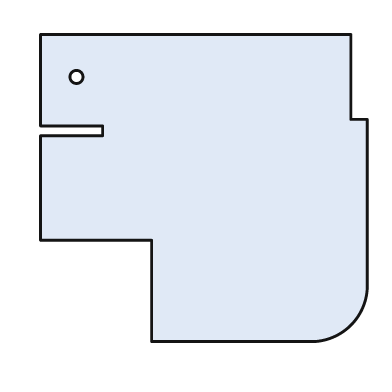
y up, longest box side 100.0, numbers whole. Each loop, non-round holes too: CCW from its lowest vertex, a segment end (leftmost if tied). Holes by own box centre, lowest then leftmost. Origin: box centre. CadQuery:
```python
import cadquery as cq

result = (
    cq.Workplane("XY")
    .moveTo(-16.0, -47.0)
    .lineTo(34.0, -47.0)
    .threePointArc((45.0, -42.0), (50.0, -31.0))
    .lineTo(50.0, 21.0)
    .lineTo(45.0, 21.0)
    .lineTo(45.0, 47.0)
    .lineTo(-50.0, 47.0)
    .lineTo(-50.0, 19.0)
    .lineTo(-31.0, 19.0)
    .lineTo(-31.0, 16.0)
    .lineTo(-50.0, 16.0)
    .lineTo(-50.0, -16.0)
    .lineTo(-16.0, -16.0)
    .close()
    .moveTo(-39.0, 34.0)
    .circle(2.0)
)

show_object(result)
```